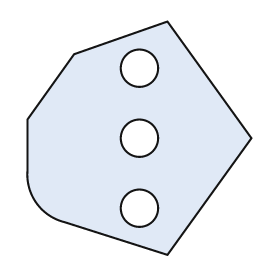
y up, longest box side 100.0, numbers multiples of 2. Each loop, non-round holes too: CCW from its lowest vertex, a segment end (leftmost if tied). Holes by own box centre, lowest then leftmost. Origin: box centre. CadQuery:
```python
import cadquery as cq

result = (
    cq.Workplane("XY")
    .moveTo(12.0, -50.0)
    .lineTo(48.0, 0.0)
    .lineTo(12.0, 50.0)
    .lineTo(-28.0, 36.0)
    .lineTo(-48.0, 8.0)
    .lineTo(-48.0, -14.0)
    .threePointArc((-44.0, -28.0), (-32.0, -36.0))
    .close()
    .moveTo(0.0, -30.0)
    .circle(8.0)
    .moveTo(0.0, 0.0)
    .circle(8.0)
    .moveTo(0.0, 30.0)
    .circle(8.0)
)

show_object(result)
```